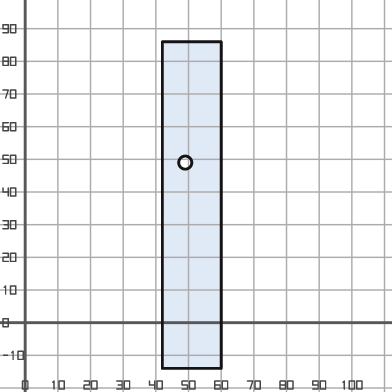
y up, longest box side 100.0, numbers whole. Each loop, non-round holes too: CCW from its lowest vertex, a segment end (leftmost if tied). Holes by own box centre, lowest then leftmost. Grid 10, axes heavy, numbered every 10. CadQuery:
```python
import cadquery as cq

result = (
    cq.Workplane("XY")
    .moveTo(42.0, -14.0)
    .lineTo(60.0, -14.0)
    .lineTo(60.0, 86.0)
    .lineTo(42.0, 86.0)
    .close()
    .moveTo(49.0, 49.0)
    .circle(2.0)
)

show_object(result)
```